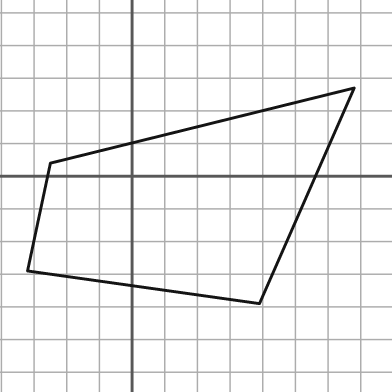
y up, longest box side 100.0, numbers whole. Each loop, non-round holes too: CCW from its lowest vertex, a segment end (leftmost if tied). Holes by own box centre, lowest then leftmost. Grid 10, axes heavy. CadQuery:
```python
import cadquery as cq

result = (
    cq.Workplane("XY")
    .moveTo(39.0, -39.0)
    .lineTo(68.0, 27.0)
    .lineTo(-25.0, 4.0)
    .lineTo(-32.0, -29.0)
    .close()
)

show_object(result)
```